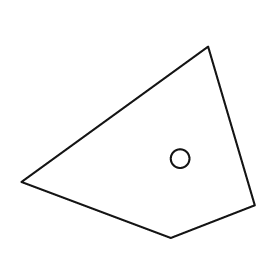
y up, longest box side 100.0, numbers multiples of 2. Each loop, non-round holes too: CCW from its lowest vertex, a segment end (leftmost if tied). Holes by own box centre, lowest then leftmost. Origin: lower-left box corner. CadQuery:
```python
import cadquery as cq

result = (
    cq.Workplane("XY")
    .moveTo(64.0, 0.0)
    .lineTo(100.0, 14.0)
    .lineTo(80.0, 82.0)
    .lineTo(0.0, 24.0)
    .close()
    .moveTo(68.0, 34.0)
    .circle(4.0)
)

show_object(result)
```